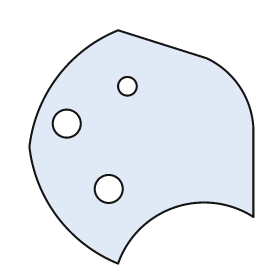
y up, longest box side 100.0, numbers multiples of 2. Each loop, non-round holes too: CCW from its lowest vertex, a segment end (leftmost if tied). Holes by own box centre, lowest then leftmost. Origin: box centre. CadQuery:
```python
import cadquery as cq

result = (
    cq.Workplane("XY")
    .moveTo(-10.0, -50.0)
    .threePointArc((14.0, -26.0), (48.0, -30.0))
    .lineTo(48.0, 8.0)
    .threePointArc((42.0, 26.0), (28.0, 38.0))
    .lineTo(-10.0, 50.0)
    .threePointArc((-36.0, 30.0), (-48.0, 0.0))
    .threePointArc((-36.0, -30.0), (-10.0, -50.0))
    .close()
    .moveTo(-14.0, -18.0)
    .circle(6.0)
    .moveTo(-32.0, 10.0)
    .circle(6.0)
    .moveTo(-6.0, 26.0)
    .circle(4.0)
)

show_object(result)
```